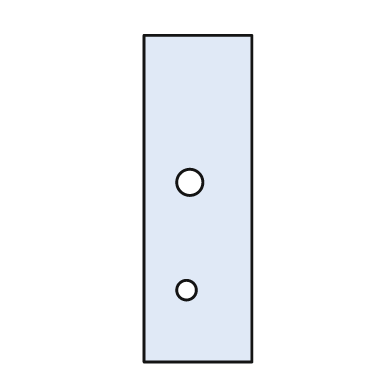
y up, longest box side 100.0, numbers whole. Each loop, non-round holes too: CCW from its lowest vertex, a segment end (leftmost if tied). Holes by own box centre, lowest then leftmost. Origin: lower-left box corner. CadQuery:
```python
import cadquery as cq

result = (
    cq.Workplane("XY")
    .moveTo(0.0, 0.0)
    .lineTo(33.0, 0.0)
    .lineTo(33.0, 100.0)
    .lineTo(0.0, 100.0)
    .close()
    .moveTo(13.0, 22.0)
    .circle(3.0)
    .moveTo(14.0, 55.0)
    .circle(4.0)
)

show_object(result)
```